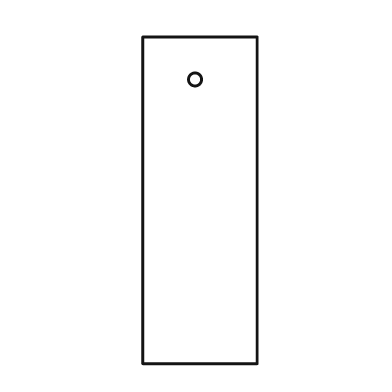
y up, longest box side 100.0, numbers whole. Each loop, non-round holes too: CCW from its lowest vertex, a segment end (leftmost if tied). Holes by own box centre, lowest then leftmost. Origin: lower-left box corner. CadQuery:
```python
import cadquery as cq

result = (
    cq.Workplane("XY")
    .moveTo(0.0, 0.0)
    .lineTo(35.0, 0.0)
    .lineTo(35.0, 100.0)
    .lineTo(0.0, 100.0)
    .close()
    .moveTo(16.0, 87.0)
    .circle(2.0)
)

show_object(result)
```